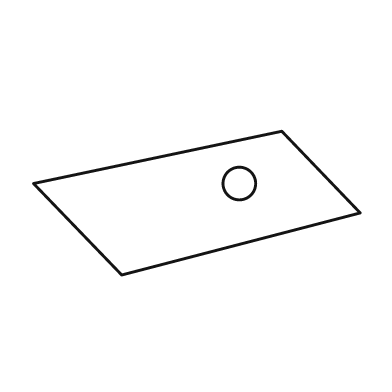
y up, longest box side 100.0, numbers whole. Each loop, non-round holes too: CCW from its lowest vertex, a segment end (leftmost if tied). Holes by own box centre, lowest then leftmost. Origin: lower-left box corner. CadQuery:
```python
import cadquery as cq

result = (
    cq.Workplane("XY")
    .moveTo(27.0, 0.0)
    .lineTo(100.0, 19.0)
    .lineTo(76.0, 44.0)
    .lineTo(0.0, 28.0)
    .close()
    .moveTo(63.0, 28.0)
    .circle(5.0)
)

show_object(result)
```